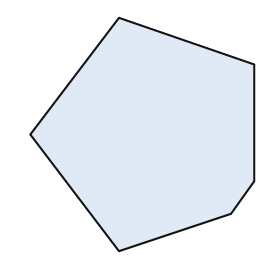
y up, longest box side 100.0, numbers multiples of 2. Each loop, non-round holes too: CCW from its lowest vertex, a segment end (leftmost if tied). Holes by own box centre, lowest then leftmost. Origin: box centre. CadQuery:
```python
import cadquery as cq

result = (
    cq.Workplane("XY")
    .moveTo(-10.0, -50.0)
    .lineTo(38.0, -34.0)
    .lineTo(48.0, -20.0)
    .lineTo(48.0, 30.0)
    .lineTo(-10.0, 50.0)
    .lineTo(-48.0, 0.0)
    .close()
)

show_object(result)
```